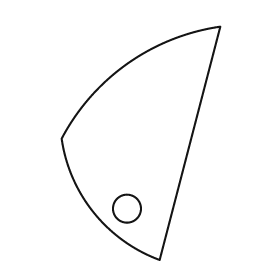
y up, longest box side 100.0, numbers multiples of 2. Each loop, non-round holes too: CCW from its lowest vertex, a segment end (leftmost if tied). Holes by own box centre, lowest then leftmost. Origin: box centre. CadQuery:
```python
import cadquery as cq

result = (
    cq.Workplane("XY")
    .moveTo(8.0, -50.0)
    .lineTo(34.0, 50.0)
    .threePointArc((-6.0, 34.0), (-34.0, 2.0))
    .threePointArc((-20.0, -30.0), (8.0, -50.0))
    .close()
    .moveTo(-6.0, -28.0)
    .circle(6.0)
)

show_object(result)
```